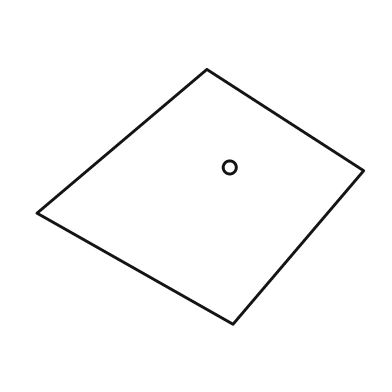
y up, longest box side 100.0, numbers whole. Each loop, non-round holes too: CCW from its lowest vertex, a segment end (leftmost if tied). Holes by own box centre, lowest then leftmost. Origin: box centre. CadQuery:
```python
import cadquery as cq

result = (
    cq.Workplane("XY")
    .moveTo(10.0, -39.0)
    .lineTo(50.0, 8.0)
    .lineTo(2.0, 39.0)
    .lineTo(-50.0, -5.0)
    .close()
    .moveTo(9.0, 9.0)
    .circle(2.0)
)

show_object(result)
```